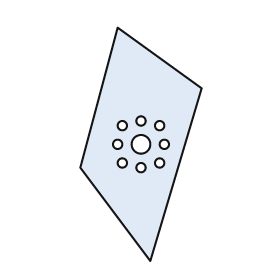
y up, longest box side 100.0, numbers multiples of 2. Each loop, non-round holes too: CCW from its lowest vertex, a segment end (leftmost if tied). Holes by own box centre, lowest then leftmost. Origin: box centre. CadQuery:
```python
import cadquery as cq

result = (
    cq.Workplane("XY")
    .moveTo(4.0, -50.0)
    .lineTo(26.0, 24.0)
    .lineTo(-10.0, 50.0)
    .lineTo(-26.0, -10.0)
    .close()
    .moveTo(0.0, -10.0)
    .circle(2.0)
    .moveTo(-8.0, -8.0)
    .circle(2.0)
    .moveTo(8.0, -8.0)
    .circle(2.0)
    .moveTo(-10.0, 0.0)
    .circle(2.0)
    .moveTo(0.0, 0.0)
    .circle(4.0)
    .moveTo(10.0, 0.0)
    .circle(2.0)
    .moveTo(-8.0, 8.0)
    .circle(2.0)
    .moveTo(8.0, 8.0)
    .circle(2.0)
    .moveTo(0.0, 10.0)
    .circle(2.0)
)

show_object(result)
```